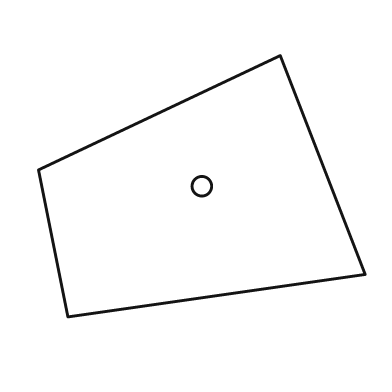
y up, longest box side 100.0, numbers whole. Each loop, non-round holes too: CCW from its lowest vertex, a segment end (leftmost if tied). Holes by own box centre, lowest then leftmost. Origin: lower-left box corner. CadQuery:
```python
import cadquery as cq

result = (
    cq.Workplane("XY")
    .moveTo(9.0, 0.0)
    .lineTo(100.0, 13.0)
    .lineTo(74.0, 80.0)
    .lineTo(0.0, 45.0)
    .close()
    .moveTo(50.0, 40.0)
    .circle(3.0)
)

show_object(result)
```